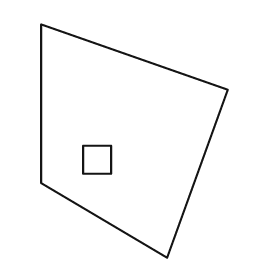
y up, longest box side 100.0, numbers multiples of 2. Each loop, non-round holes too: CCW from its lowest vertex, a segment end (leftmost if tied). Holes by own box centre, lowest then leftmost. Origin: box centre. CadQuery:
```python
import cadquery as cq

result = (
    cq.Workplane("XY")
    .moveTo(14.0, -50.0)
    .lineTo(40.0, 22.0)
    .lineTo(-40.0, 50.0)
    .lineTo(-40.0, -18.0)
    .close()
    .moveTo(-22.0, -14.0)
    .lineTo(-10.0, -14.0)
    .lineTo(-10.0, -2.0)
    .lineTo(-22.0, -2.0)
    .close()
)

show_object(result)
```